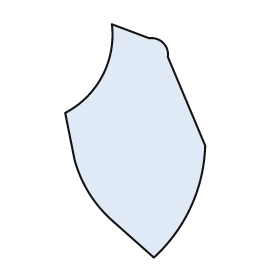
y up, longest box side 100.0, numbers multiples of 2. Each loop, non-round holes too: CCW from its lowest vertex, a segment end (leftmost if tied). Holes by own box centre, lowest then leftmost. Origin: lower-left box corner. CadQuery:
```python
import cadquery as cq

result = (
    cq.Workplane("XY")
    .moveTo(38.0, 0.0)
    .threePointArc((54.0, 22.0), (60.0, 48.0))
    .lineTo(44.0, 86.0)
    .threePointArc((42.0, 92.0), (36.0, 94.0))
    .lineTo(20.0, 100.0)
    .threePointArc((16.0, 78.0), (0.0, 62.0))
    .lineTo(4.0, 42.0)
    .threePointArc((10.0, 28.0), (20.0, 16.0))
    .close()
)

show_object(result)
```